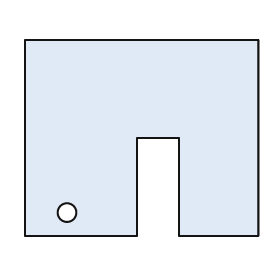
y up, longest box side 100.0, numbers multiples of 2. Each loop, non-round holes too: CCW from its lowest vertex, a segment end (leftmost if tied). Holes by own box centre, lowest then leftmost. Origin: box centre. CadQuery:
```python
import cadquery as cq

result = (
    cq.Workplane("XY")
    .moveTo(-50.0, -42.0)
    .lineTo(-2.0, -42.0)
    .lineTo(-2.0, 0.0)
    .lineTo(16.0, 0.0)
    .lineTo(16.0, -42.0)
    .lineTo(50.0, -42.0)
    .lineTo(50.0, 42.0)
    .lineTo(-50.0, 42.0)
    .close()
    .moveTo(-32.0, -32.0)
    .circle(4.0)
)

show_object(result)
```